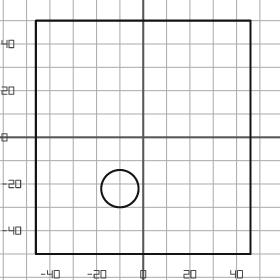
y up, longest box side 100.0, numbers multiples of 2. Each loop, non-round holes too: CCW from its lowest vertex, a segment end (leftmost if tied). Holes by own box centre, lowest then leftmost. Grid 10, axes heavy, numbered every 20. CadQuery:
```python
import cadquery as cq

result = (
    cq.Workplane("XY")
    .moveTo(-46.0, -50.0)
    .lineTo(46.0, -50.0)
    .lineTo(46.0, 50.0)
    .lineTo(-46.0, 50.0)
    .close()
    .moveTo(-10.0, -22.0)
    .circle(8.0)
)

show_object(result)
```